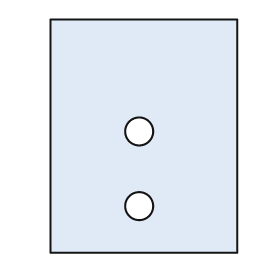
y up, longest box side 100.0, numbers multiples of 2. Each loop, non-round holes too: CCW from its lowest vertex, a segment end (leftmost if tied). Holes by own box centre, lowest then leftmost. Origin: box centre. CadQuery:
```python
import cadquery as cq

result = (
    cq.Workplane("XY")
    .moveTo(-40.0, -50.0)
    .lineTo(40.0, -50.0)
    .lineTo(40.0, 50.0)
    .lineTo(-40.0, 50.0)
    .close()
    .moveTo(-2.0, -30.0)
    .circle(6.0)
    .moveTo(-2.0, 2.0)
    .circle(6.0)
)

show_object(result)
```